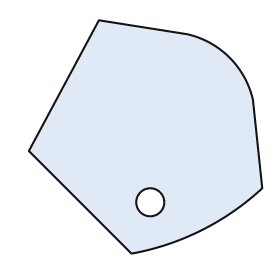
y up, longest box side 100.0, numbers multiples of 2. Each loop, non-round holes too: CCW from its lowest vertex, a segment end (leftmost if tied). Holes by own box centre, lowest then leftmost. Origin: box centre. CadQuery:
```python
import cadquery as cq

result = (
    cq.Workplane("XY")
    .moveTo(-6.0, -50.0)
    .threePointArc((24.0, -40.0), (50.0, -22.0))
    .lineTo(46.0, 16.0)
    .threePointArc((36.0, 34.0), (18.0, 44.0))
    .lineTo(-20.0, 50.0)
    .lineTo(-50.0, -6.0)
    .close()
    .moveTo(2.0, -28.0)
    .circle(6.0)
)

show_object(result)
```